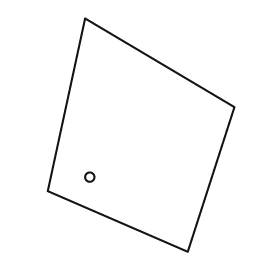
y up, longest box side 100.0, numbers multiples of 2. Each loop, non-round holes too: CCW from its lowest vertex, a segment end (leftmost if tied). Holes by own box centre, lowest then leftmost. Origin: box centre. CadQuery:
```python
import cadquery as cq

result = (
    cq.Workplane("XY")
    .moveTo(20.0, -50.0)
    .lineTo(40.0, 12.0)
    .lineTo(-24.0, 50.0)
    .lineTo(-40.0, -24.0)
    .close()
    .moveTo(-22.0, -18.0)
    .circle(2.0)
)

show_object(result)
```